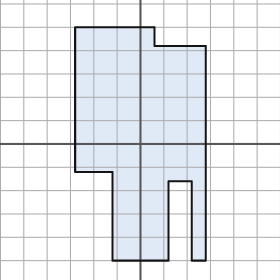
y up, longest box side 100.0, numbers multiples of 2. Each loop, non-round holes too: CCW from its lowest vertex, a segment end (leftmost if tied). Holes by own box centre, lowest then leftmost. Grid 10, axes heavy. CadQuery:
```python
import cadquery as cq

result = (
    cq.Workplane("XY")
    .moveTo(-12.0, -50.0)
    .lineTo(12.0, -50.0)
    .lineTo(12.0, -16.0)
    .lineTo(22.0, -16.0)
    .lineTo(22.0, -50.0)
    .lineTo(28.0, -50.0)
    .lineTo(28.0, 42.0)
    .lineTo(6.0, 42.0)
    .lineTo(6.0, 50.0)
    .lineTo(-28.0, 50.0)
    .lineTo(-28.0, -12.0)
    .lineTo(-12.0, -12.0)
    .close()
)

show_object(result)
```